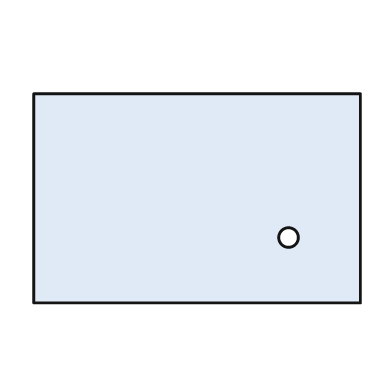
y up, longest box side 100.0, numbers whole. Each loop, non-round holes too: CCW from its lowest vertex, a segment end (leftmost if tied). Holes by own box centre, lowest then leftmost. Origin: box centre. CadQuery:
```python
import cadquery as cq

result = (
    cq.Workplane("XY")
    .moveTo(-50.0, -32.0)
    .lineTo(50.0, -32.0)
    .lineTo(50.0, 32.0)
    .lineTo(-50.0, 32.0)
    .close()
    .moveTo(28.0, -12.0)
    .circle(3.0)
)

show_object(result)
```